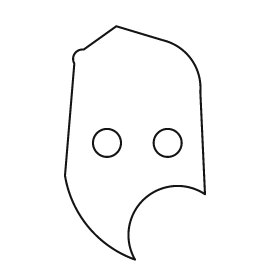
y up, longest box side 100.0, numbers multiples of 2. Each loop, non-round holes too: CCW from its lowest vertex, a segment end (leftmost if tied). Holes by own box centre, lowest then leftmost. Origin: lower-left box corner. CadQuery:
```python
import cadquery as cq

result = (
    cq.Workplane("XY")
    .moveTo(30.0, 0.0)
    .threePointArc((34.0, 26.0), (60.0, 28.0))
    .lineTo(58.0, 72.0)
    .threePointArc((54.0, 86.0), (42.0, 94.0))
    .lineTo(22.0, 100.0)
    .lineTo(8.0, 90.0)
    .threePointArc((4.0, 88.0), (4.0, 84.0))
    .lineTo(0.0, 36.0)
    .threePointArc((10.0, 14.0), (30.0, 0.0))
    .close()
    .moveTo(18.0, 50.0)
    .circle(6.0)
    .moveTo(44.0, 50.0)
    .circle(6.0)
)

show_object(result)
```